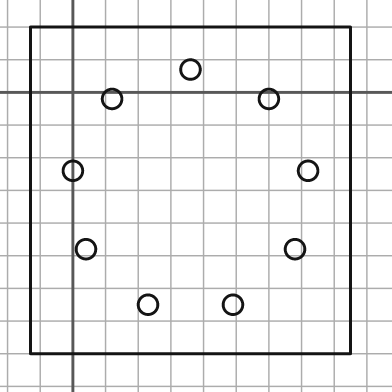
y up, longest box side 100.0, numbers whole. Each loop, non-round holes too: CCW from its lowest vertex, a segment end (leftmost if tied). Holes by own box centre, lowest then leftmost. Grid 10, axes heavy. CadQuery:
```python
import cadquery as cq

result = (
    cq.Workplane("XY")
    .moveTo(-13.0, -80.0)
    .lineTo(85.0, -80.0)
    .lineTo(85.0, 20.0)
    .lineTo(-13.0, 20.0)
    .close()
    .moveTo(23.0, -65.0)
    .circle(3.0)
    .moveTo(49.0, -65.0)
    .circle(3.0)
    .moveTo(4.0, -48.0)
    .circle(3.0)
    .moveTo(68.0, -48.0)
    .circle(3.0)
    .moveTo(0.0, -24.0)
    .circle(3.0)
    .moveTo(72.0, -24.0)
    .circle(3.0)
    .moveTo(12.0, -2.0)
    .circle(3.0)
    .moveTo(60.0, -2.0)
    .circle(3.0)
    .moveTo(36.0, 7.0)
    .circle(3.0)
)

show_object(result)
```